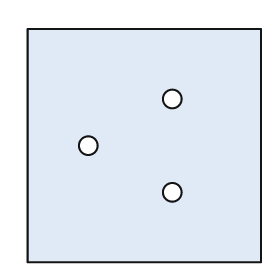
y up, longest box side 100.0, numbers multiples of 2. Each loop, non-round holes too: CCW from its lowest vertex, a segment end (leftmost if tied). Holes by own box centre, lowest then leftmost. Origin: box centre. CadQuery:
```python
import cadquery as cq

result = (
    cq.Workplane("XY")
    .moveTo(-50.0, -50.0)
    .lineTo(50.0, -50.0)
    .lineTo(50.0, 50.0)
    .lineTo(-50.0, 50.0)
    .close()
    .moveTo(12.0, -20.0)
    .circle(4.0)
    .moveTo(-24.0, 0.0)
    .circle(4.0)
    .moveTo(12.0, 20.0)
    .circle(4.0)
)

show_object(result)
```